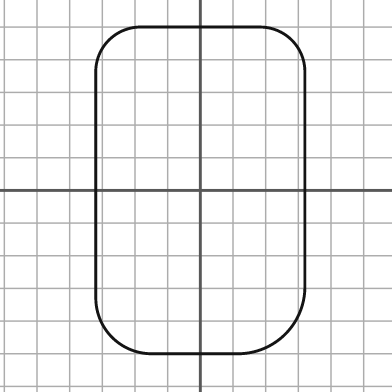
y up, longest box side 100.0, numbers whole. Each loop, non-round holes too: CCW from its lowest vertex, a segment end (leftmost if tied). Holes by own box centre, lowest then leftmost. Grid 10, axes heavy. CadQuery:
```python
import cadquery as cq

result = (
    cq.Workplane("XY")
    .moveTo(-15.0, -50.0)
    .lineTo(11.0, -50.0)
    .threePointArc((26.0, -44.0), (32.0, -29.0))
    .lineTo(32.0, 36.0)
    .threePointArc((28.0, 46.0), (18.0, 50.0))
    .lineTo(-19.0, 50.0)
    .threePointArc((-28.0, 46.0), (-32.0, 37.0))
    .lineTo(-32.0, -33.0)
    .threePointArc((-27.0, -45.0), (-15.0, -50.0))
    .close()
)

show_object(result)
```